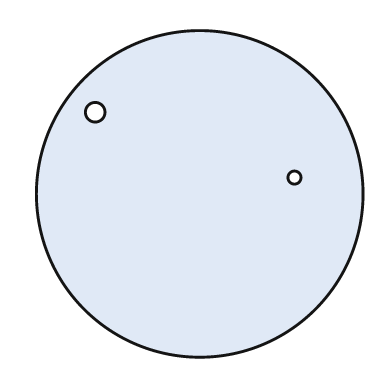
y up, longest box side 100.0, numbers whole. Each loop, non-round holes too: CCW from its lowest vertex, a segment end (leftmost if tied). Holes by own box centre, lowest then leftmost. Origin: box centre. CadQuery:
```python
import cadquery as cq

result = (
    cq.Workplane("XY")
    .moveTo(0.0, 0.0)
    .circle(50.0)
    .moveTo(29.0, 5.0)
    .circle(2.0)
    .moveTo(-32.0, 25.0)
    .circle(3.0)
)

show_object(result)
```